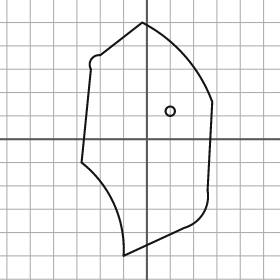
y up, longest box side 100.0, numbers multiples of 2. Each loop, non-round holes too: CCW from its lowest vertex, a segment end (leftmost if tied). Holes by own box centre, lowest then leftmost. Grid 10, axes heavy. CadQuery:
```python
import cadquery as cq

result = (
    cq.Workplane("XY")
    .moveTo(-10.0, -50.0)
    .lineTo(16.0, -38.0)
    .threePointArc((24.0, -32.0), (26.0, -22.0))
    .lineTo(28.0, 16.0)
    .threePointArc((16.0, 36.0), (-2.0, 50.0))
    .lineTo(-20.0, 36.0)
    .threePointArc((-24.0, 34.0), (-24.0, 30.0))
    .lineTo(-28.0, -10.0)
    .threePointArc((-14.0, -28.0), (-10.0, -50.0))
    .close()
    .moveTo(10.0, 12.0)
    .circle(2.0)
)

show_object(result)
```